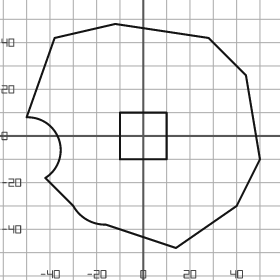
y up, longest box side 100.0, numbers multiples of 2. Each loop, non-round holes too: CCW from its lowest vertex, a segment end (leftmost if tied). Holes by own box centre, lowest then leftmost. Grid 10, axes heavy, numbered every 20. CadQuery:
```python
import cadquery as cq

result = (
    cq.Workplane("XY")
    .moveTo(14.0, -48.0)
    .lineTo(40.0, -30.0)
    .lineTo(50.0, -10.0)
    .lineTo(44.0, 26.0)
    .lineTo(28.0, 42.0)
    .lineTo(-12.0, 48.0)
    .lineTo(-38.0, 42.0)
    .lineTo(-50.0, 8.0)
    .threePointArc((-36.0, -2.0), (-42.0, -18.0))
    .lineTo(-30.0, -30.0)
    .threePointArc((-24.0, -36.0), (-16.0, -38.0))
    .close()
    .moveTo(-10.0, -10.0)
    .lineTo(10.0, -10.0)
    .lineTo(10.0, 10.0)
    .lineTo(-10.0, 10.0)
    .close()
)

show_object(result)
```